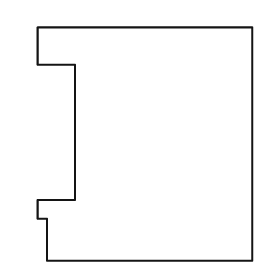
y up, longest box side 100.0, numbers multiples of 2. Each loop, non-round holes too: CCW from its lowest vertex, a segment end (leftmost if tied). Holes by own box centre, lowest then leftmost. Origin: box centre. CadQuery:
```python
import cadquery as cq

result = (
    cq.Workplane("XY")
    .moveTo(-42.0, -50.0)
    .lineTo(46.0, -50.0)
    .lineTo(46.0, 50.0)
    .lineTo(-46.0, 50.0)
    .lineTo(-46.0, 34.0)
    .lineTo(-30.0, 34.0)
    .lineTo(-30.0, -24.0)
    .lineTo(-46.0, -24.0)
    .lineTo(-46.0, -32.0)
    .lineTo(-42.0, -32.0)
    .close()
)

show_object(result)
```